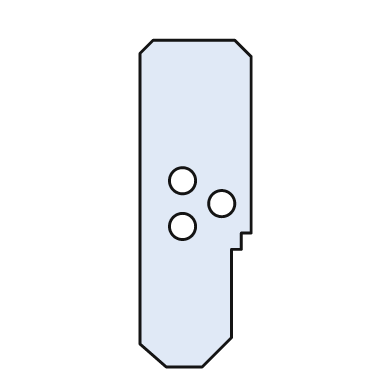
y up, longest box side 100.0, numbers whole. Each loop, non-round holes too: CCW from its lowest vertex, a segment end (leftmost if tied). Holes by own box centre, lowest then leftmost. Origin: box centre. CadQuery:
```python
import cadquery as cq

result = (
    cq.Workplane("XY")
    .moveTo(-9.0, -50.0)
    .lineTo(2.0, -50.0)
    .lineTo(11.0, -41.0)
    .lineTo(11.0, -14.0)
    .lineTo(14.0, -14.0)
    .lineTo(14.0, -9.0)
    .lineTo(17.0, -9.0)
    .lineTo(17.0, 45.0)
    .lineTo(12.0, 50.0)
    .lineTo(-13.0, 50.0)
    .lineTo(-17.0, 46.0)
    .lineTo(-17.0, -43.0)
    .close()
    .moveTo(-4.0, -7.0)
    .circle(4.0)
    .moveTo(8.0, 0.0)
    .circle(4.0)
    .moveTo(-4.0, 7.0)
    .circle(4.0)
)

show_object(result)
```